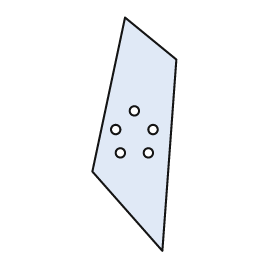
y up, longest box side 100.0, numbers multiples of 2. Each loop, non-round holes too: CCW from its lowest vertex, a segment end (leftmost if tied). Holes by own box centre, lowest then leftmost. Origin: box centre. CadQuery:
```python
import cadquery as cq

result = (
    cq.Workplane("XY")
    .moveTo(12.0, -50.0)
    .lineTo(18.0, 32.0)
    .lineTo(-4.0, 50.0)
    .lineTo(-18.0, -16.0)
    .close()
    .moveTo(-6.0, -8.0)
    .circle(2.0)
    .moveTo(6.0, -8.0)
    .circle(2.0)
    .moveTo(-8.0, 2.0)
    .circle(2.0)
    .moveTo(8.0, 2.0)
    .circle(2.0)
    .moveTo(0.0, 10.0)
    .circle(2.0)
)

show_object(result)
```